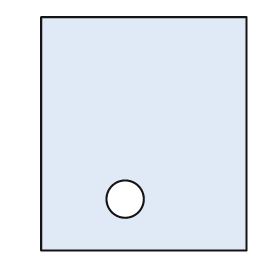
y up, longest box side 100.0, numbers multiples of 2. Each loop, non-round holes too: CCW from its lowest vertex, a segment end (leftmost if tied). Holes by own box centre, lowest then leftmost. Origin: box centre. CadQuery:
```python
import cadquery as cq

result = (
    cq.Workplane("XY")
    .moveTo(-44.0, -50.0)
    .lineTo(44.0, -50.0)
    .lineTo(44.0, 50.0)
    .lineTo(-44.0, 50.0)
    .close()
    .moveTo(-8.0, -28.0)
    .circle(8.0)
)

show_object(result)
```